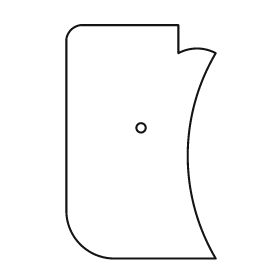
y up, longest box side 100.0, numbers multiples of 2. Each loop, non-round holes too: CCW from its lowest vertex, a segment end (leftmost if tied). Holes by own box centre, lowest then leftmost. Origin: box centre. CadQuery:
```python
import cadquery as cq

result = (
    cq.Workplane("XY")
    .moveTo(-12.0, -50.0)
    .lineTo(32.0, -50.0)
    .threePointArc((20.0, -6.0), (32.0, 38.0))
    .threePointArc((24.0, 40.0), (16.0, 38.0))
    .lineTo(16.0, 50.0)
    .lineTo(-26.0, 50.0)
    .threePointArc((-30.0, 48.0), (-32.0, 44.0))
    .lineTo(-32.0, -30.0)
    .threePointArc((-26.0, -44.0), (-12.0, -50.0))
    .close()
    .moveTo(0.0, 6.0)
    .circle(2.0)
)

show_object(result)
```